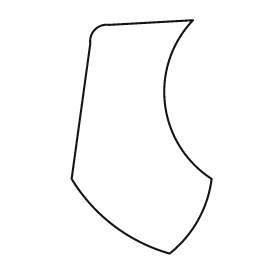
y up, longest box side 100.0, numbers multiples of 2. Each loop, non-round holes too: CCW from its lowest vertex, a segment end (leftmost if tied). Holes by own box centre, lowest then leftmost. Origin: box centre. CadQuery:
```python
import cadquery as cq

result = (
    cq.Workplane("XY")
    .moveTo(12.0, -50.0)
    .threePointArc((24.0, -36.0), (30.0, -18.0))
    .threePointArc((10.0, 14.0), (22.0, 50.0))
    .lineTo(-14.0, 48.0)
    .threePointArc((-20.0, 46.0), (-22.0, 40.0))
    .lineTo(-30.0, -18.0)
    .threePointArc((-12.0, -38.0), (12.0, -50.0))
    .close()
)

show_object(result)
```